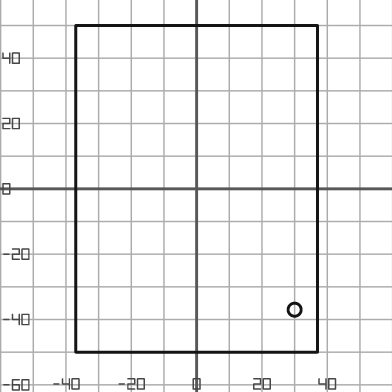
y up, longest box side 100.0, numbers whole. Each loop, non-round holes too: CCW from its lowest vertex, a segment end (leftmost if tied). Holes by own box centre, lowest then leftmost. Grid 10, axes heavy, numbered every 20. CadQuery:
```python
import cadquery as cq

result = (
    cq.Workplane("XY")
    .moveTo(-37.0, -50.0)
    .lineTo(37.0, -50.0)
    .lineTo(37.0, 50.0)
    .lineTo(-37.0, 50.0)
    .close()
    .moveTo(30.0, -37.0)
    .circle(2.0)
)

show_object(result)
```